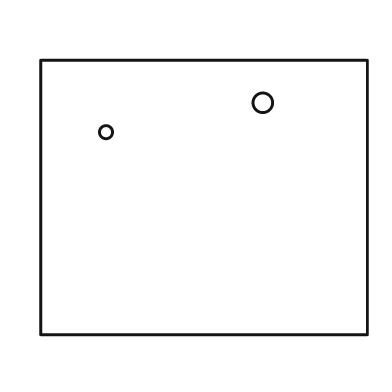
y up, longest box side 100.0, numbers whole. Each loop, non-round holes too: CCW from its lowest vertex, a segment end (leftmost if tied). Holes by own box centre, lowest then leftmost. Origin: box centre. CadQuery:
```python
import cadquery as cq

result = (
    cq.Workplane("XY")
    .moveTo(-50.0, -42.0)
    .lineTo(50.0, -42.0)
    .lineTo(50.0, 42.0)
    .lineTo(-50.0, 42.0)
    .close()
    .moveTo(-30.0, 20.0)
    .circle(2.0)
    .moveTo(18.0, 29.0)
    .circle(3.0)
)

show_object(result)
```